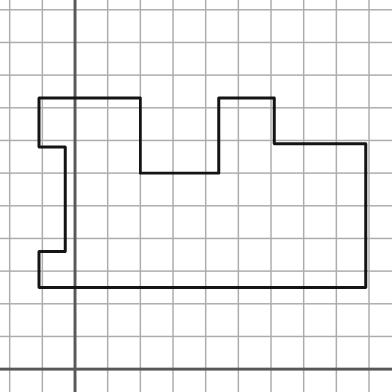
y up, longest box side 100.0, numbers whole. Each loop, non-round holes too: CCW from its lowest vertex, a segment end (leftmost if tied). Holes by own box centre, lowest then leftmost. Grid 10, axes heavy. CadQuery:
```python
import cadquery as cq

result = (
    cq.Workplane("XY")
    .moveTo(-11.0, 25.0)
    .lineTo(89.0, 25.0)
    .lineTo(89.0, 69.0)
    .lineTo(61.0, 69.0)
    .lineTo(61.0, 83.0)
    .lineTo(44.0, 83.0)
    .lineTo(44.0, 60.0)
    .lineTo(20.0, 60.0)
    .lineTo(20.0, 83.0)
    .lineTo(-11.0, 83.0)
    .lineTo(-11.0, 68.0)
    .lineTo(-3.0, 68.0)
    .lineTo(-3.0, 36.0)
    .lineTo(-11.0, 36.0)
    .close()
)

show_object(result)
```